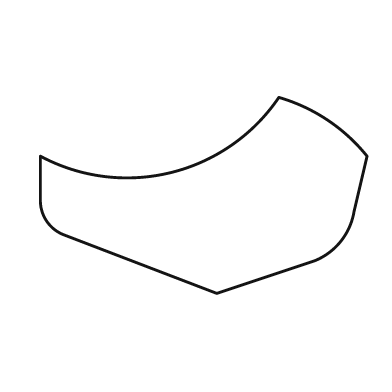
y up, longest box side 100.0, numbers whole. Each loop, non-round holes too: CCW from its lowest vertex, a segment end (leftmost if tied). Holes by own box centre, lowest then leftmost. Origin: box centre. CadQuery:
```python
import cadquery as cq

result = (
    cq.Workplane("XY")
    .moveTo(4.0, -30.0)
    .lineTo(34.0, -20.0)
    .threePointArc((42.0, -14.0), (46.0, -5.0))
    .lineTo(50.0, 12.0)
    .threePointArc((38.0, 23.0), (23.0, 30.0))
    .threePointArc((-10.0, 7.0), (-50.0, 12.0))
    .lineTo(-50.0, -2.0)
    .threePointArc((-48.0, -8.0), (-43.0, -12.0))
    .close()
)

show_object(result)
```